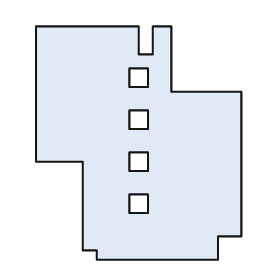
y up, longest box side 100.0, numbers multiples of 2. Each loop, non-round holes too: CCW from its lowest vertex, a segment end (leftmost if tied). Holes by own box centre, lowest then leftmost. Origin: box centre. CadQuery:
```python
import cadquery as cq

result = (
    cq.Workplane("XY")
    .moveTo(-18.0, -50.0)
    .lineTo(34.0, -50.0)
    .lineTo(34.0, -40.0)
    .lineTo(44.0, -40.0)
    .lineTo(44.0, 22.0)
    .lineTo(14.0, 22.0)
    .lineTo(14.0, 50.0)
    .lineTo(6.0, 50.0)
    .lineTo(6.0, 38.0)
    .lineTo(0.0, 38.0)
    .lineTo(0.0, 50.0)
    .lineTo(-44.0, 50.0)
    .lineTo(-44.0, -8.0)
    .lineTo(-24.0, -8.0)
    .lineTo(-24.0, -46.0)
    .lineTo(-18.0, -46.0)
    .close()
    .moveTo(-4.0, -30.0)
    .lineTo(4.0, -30.0)
    .lineTo(4.0, -22.0)
    .lineTo(-4.0, -22.0)
    .close()
    .moveTo(-4.0, -12.0)
    .lineTo(4.0, -12.0)
    .lineTo(4.0, -4.0)
    .lineTo(-4.0, -4.0)
    .close()
    .moveTo(-4.0, 6.0)
    .lineTo(4.0, 6.0)
    .lineTo(4.0, 14.0)
    .lineTo(-4.0, 14.0)
    .close()
    .moveTo(-4.0, 24.0)
    .lineTo(4.0, 24.0)
    .lineTo(4.0, 32.0)
    .lineTo(-4.0, 32.0)
    .close()
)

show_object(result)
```